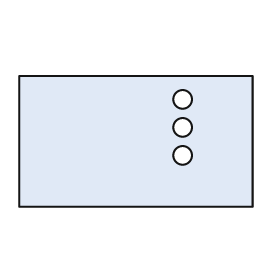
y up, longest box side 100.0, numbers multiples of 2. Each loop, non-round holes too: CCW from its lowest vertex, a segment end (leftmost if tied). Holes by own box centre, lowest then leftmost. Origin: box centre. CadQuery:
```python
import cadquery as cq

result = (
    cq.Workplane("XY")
    .moveTo(-50.0, -28.0)
    .lineTo(50.0, -28.0)
    .lineTo(50.0, 28.0)
    .lineTo(-50.0, 28.0)
    .close()
    .moveTo(20.0, -6.0)
    .circle(4.0)
    .moveTo(20.0, 6.0)
    .circle(4.0)
    .moveTo(20.0, 18.0)
    .circle(4.0)
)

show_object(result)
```